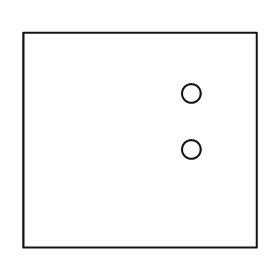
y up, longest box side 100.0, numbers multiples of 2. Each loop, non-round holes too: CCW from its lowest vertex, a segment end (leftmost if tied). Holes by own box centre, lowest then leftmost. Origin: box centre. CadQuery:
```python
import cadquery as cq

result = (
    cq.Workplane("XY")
    .moveTo(-50.0, -46.0)
    .lineTo(50.0, -46.0)
    .lineTo(50.0, 46.0)
    .lineTo(-50.0, 46.0)
    .close()
    .moveTo(22.0, -4.0)
    .circle(4.0)
    .moveTo(22.0, 20.0)
    .circle(4.0)
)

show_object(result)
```